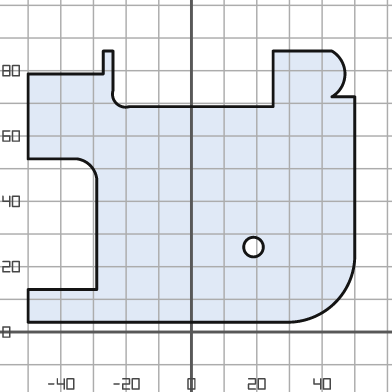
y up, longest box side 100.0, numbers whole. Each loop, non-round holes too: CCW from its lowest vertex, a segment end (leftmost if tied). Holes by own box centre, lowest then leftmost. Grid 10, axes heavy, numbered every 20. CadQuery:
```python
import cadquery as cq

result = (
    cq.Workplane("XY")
    .moveTo(-50.0, 3.0)
    .lineTo(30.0, 3.0)
    .threePointArc((44.0, 9.0), (50.0, 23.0))
    .lineTo(50.0, 72.0)
    .lineTo(43.0, 72.0)
    .threePointArc((47.0, 79.0), (43.0, 86.0))
    .lineTo(25.0, 86.0)
    .lineTo(25.0, 69.0)
    .lineTo(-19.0, 69.0)
    .threePointArc((-23.0, 70.0), (-24.0, 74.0))
    .lineTo(-24.0, 86.0)
    .lineTo(-27.0, 86.0)
    .lineTo(-27.0, 79.0)
    .lineTo(-50.0, 79.0)
    .lineTo(-50.0, 53.0)
    .lineTo(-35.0, 53.0)
    .threePointArc((-31.0, 51.0), (-29.0, 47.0))
    .lineTo(-29.0, 13.0)
    .lineTo(-50.0, 13.0)
    .close()
    .moveTo(19.0, 26.0)
    .circle(3.0)
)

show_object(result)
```